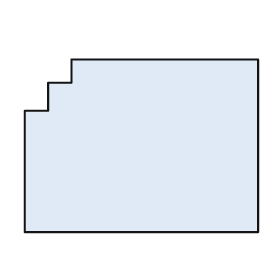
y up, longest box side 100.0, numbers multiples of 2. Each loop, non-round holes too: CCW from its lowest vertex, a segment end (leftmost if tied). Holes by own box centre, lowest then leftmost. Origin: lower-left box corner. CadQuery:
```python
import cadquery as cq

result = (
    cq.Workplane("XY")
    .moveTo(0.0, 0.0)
    .lineTo(100.0, 0.0)
    .lineTo(100.0, 74.0)
    .lineTo(20.0, 74.0)
    .lineTo(20.0, 64.0)
    .lineTo(10.0, 64.0)
    .lineTo(10.0, 52.0)
    .lineTo(0.0, 52.0)
    .close()
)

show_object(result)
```